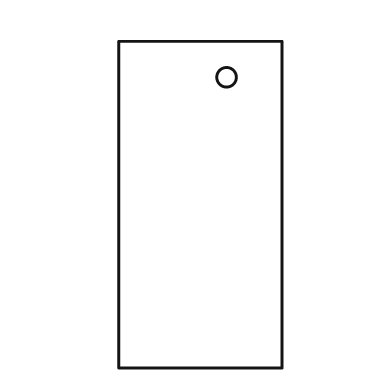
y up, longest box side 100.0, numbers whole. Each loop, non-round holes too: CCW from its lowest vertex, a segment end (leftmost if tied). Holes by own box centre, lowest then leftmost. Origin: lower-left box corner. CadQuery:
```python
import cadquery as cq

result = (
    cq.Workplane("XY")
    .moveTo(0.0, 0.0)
    .lineTo(50.0, 0.0)
    .lineTo(50.0, 100.0)
    .lineTo(0.0, 100.0)
    .close()
    .moveTo(33.0, 89.0)
    .circle(3.0)
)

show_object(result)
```